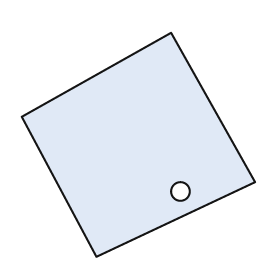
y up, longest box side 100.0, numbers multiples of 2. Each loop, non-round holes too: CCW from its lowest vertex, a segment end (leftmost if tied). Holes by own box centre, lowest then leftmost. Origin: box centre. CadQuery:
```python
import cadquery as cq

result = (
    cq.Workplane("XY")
    .moveTo(-18.0, -48.0)
    .lineTo(50.0, -16.0)
    .lineTo(14.0, 48.0)
    .lineTo(-50.0, 12.0)
    .close()
    .moveTo(18.0, -20.0)
    .circle(4.0)
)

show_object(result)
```